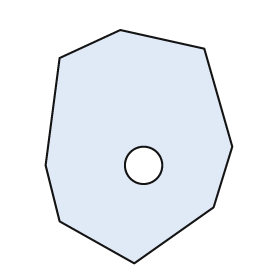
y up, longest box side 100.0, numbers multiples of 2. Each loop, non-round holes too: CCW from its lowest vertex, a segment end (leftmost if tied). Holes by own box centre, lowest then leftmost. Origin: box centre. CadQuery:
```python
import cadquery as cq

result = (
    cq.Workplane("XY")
    .moveTo(-2.0, -50.0)
    .lineTo(32.0, -26.0)
    .lineTo(40.0, 0.0)
    .lineTo(28.0, 42.0)
    .lineTo(-8.0, 50.0)
    .lineTo(-34.0, 38.0)
    .lineTo(-40.0, -8.0)
    .lineTo(-34.0, -32.0)
    .close()
    .moveTo(2.0, -8.0)
    .circle(8.0)
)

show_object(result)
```